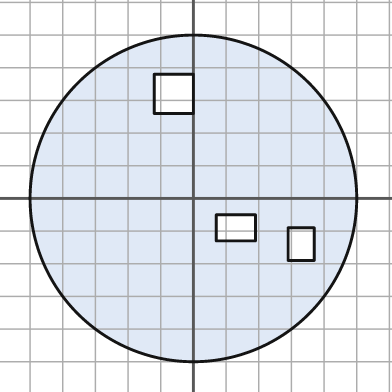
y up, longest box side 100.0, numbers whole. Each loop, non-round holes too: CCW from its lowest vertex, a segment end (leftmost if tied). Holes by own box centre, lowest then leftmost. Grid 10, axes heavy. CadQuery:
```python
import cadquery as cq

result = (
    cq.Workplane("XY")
    .moveTo(0.0, 0.0)
    .circle(50.0)
    .moveTo(29.0, -19.0)
    .lineTo(37.0, -19.0)
    .lineTo(37.0, -9.0)
    .lineTo(29.0, -9.0)
    .close()
    .moveTo(7.0, -13.0)
    .lineTo(19.0, -13.0)
    .lineTo(19.0, -5.0)
    .lineTo(7.0, -5.0)
    .close()
    .moveTo(-12.0, 26.0)
    .lineTo(0.0, 26.0)
    .lineTo(0.0, 38.0)
    .lineTo(-12.0, 38.0)
    .close()
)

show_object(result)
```